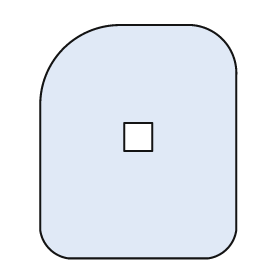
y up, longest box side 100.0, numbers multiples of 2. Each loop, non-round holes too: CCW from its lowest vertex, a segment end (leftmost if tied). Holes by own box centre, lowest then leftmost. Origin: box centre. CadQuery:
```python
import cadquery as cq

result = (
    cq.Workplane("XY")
    .moveTo(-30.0, -50.0)
    .lineTo(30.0, -50.0)
    .threePointArc((38.0, -46.0), (42.0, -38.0))
    .lineTo(42.0, 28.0)
    .threePointArc((36.0, 44.0), (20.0, 50.0))
    .lineTo(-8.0, 50.0)
    .threePointArc((-32.0, 40.0), (-42.0, 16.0))
    .lineTo(-42.0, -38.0)
    .threePointArc((-38.0, -46.0), (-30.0, -50.0))
    .close()
    .moveTo(-6.0, -4.0)
    .lineTo(6.0, -4.0)
    .lineTo(6.0, 8.0)
    .lineTo(-6.0, 8.0)
    .close()
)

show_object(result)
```